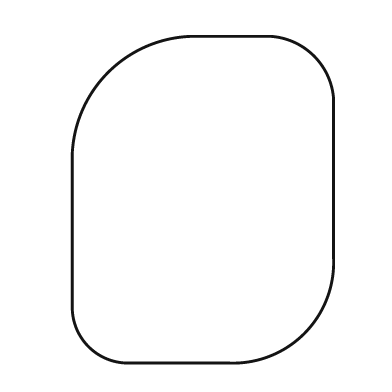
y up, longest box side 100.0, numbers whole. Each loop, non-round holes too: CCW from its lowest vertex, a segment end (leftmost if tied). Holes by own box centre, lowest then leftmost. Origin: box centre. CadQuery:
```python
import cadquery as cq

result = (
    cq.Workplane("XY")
    .moveTo(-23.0, -50.0)
    .lineTo(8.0, -50.0)
    .threePointArc((31.0, -41.0), (40.0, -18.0))
    .lineTo(40.0, 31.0)
    .threePointArc((34.0, 44.0), (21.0, 50.0))
    .lineTo(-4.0, 50.0)
    .threePointArc((-29.0, 39.0), (-40.0, 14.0))
    .lineTo(-40.0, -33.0)
    .threePointArc((-35.0, -45.0), (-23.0, -50.0))
    .close()
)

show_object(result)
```